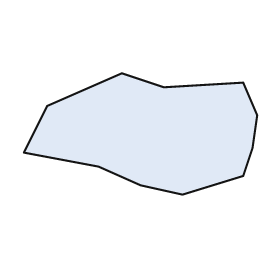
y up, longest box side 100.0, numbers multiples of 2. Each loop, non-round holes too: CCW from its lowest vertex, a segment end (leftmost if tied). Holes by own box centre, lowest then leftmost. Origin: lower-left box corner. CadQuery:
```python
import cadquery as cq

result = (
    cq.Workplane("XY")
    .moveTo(68.0, 0.0)
    .lineTo(94.0, 8.0)
    .lineTo(98.0, 20.0)
    .lineTo(100.0, 34.0)
    .lineTo(94.0, 48.0)
    .lineTo(60.0, 46.0)
    .lineTo(42.0, 52.0)
    .lineTo(10.0, 38.0)
    .lineTo(0.0, 18.0)
    .lineTo(32.0, 12.0)
    .lineTo(50.0, 4.0)
    .close()
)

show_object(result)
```